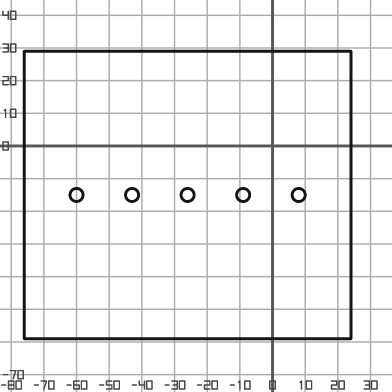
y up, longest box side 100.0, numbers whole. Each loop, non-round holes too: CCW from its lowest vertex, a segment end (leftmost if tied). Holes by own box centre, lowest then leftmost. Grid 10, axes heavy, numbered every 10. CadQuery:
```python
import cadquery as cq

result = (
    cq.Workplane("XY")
    .moveTo(-76.0, -59.0)
    .lineTo(24.0, -59.0)
    .lineTo(24.0, 29.0)
    .lineTo(-76.0, 29.0)
    .close()
    .moveTo(-60.0, -15.0)
    .circle(2.0)
    .moveTo(-43.0, -15.0)
    .circle(2.0)
    .moveTo(-26.0, -15.0)
    .circle(2.0)
    .moveTo(-9.0, -15.0)
    .circle(2.0)
    .moveTo(8.0, -15.0)
    .circle(2.0)
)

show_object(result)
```